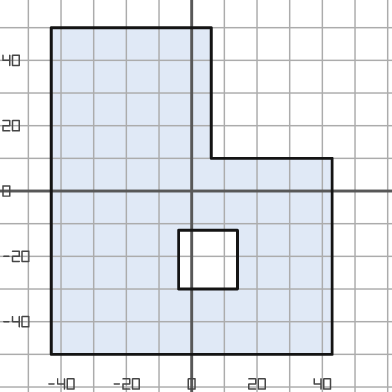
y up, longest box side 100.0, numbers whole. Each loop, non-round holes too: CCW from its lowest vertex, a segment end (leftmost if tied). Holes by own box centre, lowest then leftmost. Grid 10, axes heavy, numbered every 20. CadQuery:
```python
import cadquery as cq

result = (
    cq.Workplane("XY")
    .moveTo(-43.0, -50.0)
    .lineTo(43.0, -50.0)
    .lineTo(43.0, 10.0)
    .lineTo(6.0, 10.0)
    .lineTo(6.0, 50.0)
    .lineTo(-43.0, 50.0)
    .close()
    .moveTo(-4.0, -30.0)
    .lineTo(14.0, -30.0)
    .lineTo(14.0, -12.0)
    .lineTo(-4.0, -12.0)
    .close()
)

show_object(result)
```